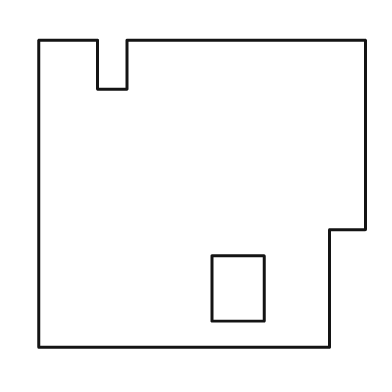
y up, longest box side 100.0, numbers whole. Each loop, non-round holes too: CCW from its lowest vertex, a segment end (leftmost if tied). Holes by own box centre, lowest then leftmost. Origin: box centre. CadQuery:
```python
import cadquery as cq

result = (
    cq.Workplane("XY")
    .moveTo(-50.0, -47.0)
    .lineTo(39.0, -47.0)
    .lineTo(39.0, -11.0)
    .lineTo(50.0, -11.0)
    .lineTo(50.0, 47.0)
    .lineTo(-23.0, 47.0)
    .lineTo(-23.0, 32.0)
    .lineTo(-32.0, 32.0)
    .lineTo(-32.0, 47.0)
    .lineTo(-50.0, 47.0)
    .close()
    .moveTo(3.0, -39.0)
    .lineTo(19.0, -39.0)
    .lineTo(19.0, -19.0)
    .lineTo(3.0, -19.0)
    .close()
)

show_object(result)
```